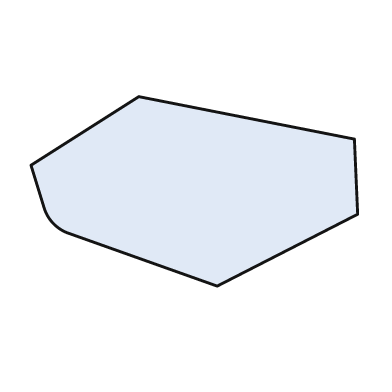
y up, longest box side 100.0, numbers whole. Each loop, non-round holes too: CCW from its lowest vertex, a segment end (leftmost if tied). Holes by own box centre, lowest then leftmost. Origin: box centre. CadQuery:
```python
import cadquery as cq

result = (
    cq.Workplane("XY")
    .moveTo(7.0, -29.0)
    .lineTo(50.0, -7.0)
    .lineTo(49.0, 16.0)
    .lineTo(-17.0, 29.0)
    .lineTo(-50.0, 8.0)
    .lineTo(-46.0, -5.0)
    .threePointArc((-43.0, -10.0), (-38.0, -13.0))
    .close()
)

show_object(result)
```